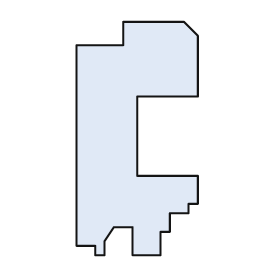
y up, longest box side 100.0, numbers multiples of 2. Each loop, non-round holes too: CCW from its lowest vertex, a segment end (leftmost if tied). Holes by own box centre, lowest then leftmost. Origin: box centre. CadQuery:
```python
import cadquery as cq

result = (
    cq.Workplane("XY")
    .moveTo(-18.0, -50.0)
    .lineTo(-14.0, -50.0)
    .lineTo(-14.0, -44.0)
    .lineTo(-10.0, -38.0)
    .lineTo(-2.0, -38.0)
    .lineTo(-2.0, -50.0)
    .lineTo(10.0, -50.0)
    .lineTo(10.0, -40.0)
    .lineTo(14.0, -40.0)
    .lineTo(14.0, -32.0)
    .lineTo(22.0, -32.0)
    .lineTo(22.0, -28.0)
    .lineTo(26.0, -28.0)
    .lineTo(26.0, -16.0)
    .lineTo(0.0, -16.0)
    .lineTo(0.0, 18.0)
    .lineTo(26.0, 18.0)
    .lineTo(26.0, 44.0)
    .lineTo(20.0, 50.0)
    .lineTo(-6.0, 50.0)
    .lineTo(-6.0, 40.0)
    .lineTo(-26.0, 40.0)
    .lineTo(-26.0, -46.0)
    .lineTo(-18.0, -46.0)
    .close()
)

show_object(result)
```